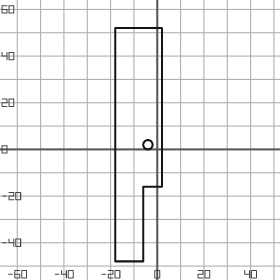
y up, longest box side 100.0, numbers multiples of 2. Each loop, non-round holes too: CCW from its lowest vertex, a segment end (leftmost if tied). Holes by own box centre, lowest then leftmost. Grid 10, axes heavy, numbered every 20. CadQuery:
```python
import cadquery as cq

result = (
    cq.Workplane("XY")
    .moveTo(-18.0, -48.0)
    .lineTo(-6.0, -48.0)
    .lineTo(-6.0, -16.0)
    .lineTo(2.0, -16.0)
    .lineTo(2.0, 52.0)
    .lineTo(-18.0, 52.0)
    .close()
    .moveTo(-4.0, 2.0)
    .circle(2.0)
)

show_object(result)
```